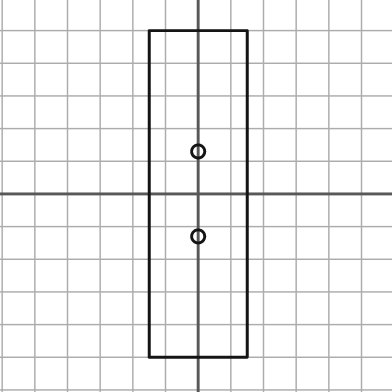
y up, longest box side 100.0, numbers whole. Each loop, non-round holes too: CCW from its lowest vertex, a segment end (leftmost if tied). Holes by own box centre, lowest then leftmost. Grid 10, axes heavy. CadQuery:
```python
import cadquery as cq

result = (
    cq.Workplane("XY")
    .moveTo(-15.0, -50.0)
    .lineTo(15.0, -50.0)
    .lineTo(15.0, 50.0)
    .lineTo(-15.0, 50.0)
    .close()
    .moveTo(0.0, -13.0)
    .circle(2.0)
    .moveTo(0.0, 13.0)
    .circle(2.0)
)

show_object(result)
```